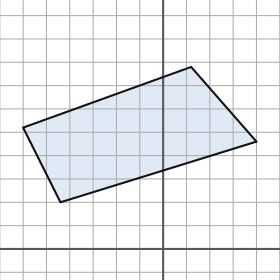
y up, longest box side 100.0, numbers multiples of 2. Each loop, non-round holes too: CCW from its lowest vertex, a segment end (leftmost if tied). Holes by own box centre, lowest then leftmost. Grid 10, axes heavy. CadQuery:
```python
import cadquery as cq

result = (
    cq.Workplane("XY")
    .moveTo(-44.0, 20.0)
    .lineTo(40.0, 46.0)
    .lineTo(12.0, 78.0)
    .lineTo(-60.0, 52.0)
    .close()
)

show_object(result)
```